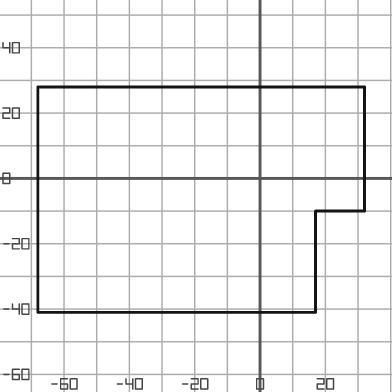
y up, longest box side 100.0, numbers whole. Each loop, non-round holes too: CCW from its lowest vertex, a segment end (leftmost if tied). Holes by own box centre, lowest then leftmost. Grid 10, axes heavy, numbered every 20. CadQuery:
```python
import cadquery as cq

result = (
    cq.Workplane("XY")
    .moveTo(-68.0, -41.0)
    .lineTo(17.0, -41.0)
    .lineTo(17.0, -10.0)
    .lineTo(32.0, -10.0)
    .lineTo(32.0, 28.0)
    .lineTo(-68.0, 28.0)
    .close()
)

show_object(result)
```